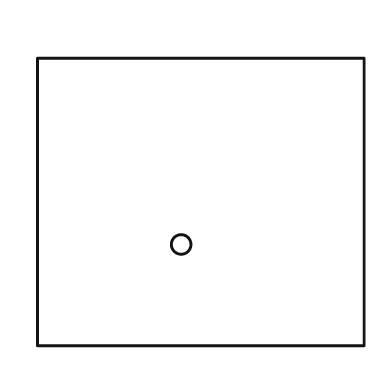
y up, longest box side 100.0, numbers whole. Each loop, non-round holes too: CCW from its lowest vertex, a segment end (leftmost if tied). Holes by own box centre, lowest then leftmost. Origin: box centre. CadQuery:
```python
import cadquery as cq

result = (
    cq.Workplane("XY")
    .moveTo(-50.0, -44.0)
    .lineTo(50.0, -44.0)
    .lineTo(50.0, 44.0)
    .lineTo(-50.0, 44.0)
    .close()
    .moveTo(-6.0, -13.0)
    .circle(3.0)
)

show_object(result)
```